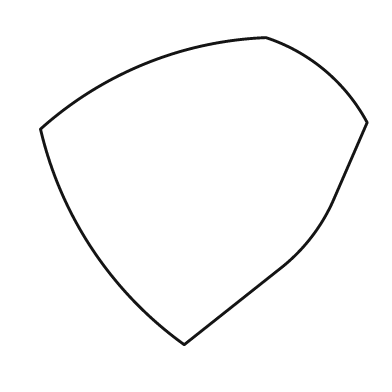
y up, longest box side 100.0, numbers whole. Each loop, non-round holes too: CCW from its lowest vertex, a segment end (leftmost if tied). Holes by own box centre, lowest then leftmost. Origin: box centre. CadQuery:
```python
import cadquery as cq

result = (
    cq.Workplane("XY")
    .moveTo(-6.0, -47.0)
    .lineTo(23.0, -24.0)
    .threePointArc((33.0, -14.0), (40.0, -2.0))
    .lineTo(50.0, 21.0)
    .threePointArc((37.0, 37.0), (19.0, 47.0))
    .threePointArc((-18.0, 39.0), (-50.0, 19.0))
    .threePointArc((-34.0, -18.0), (-6.0, -47.0))
    .close()
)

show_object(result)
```